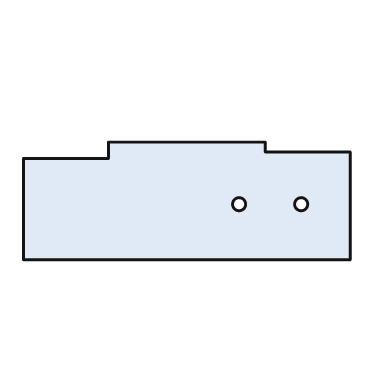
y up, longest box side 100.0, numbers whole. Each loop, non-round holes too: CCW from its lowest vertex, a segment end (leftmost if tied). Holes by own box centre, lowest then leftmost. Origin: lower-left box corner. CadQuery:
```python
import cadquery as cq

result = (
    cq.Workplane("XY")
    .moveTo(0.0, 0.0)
    .lineTo(100.0, 0.0)
    .lineTo(100.0, 33.0)
    .lineTo(74.0, 33.0)
    .lineTo(74.0, 36.0)
    .lineTo(26.0, 36.0)
    .lineTo(26.0, 31.0)
    .lineTo(0.0, 31.0)
    .close()
    .moveTo(66.0, 17.0)
    .circle(2.0)
    .moveTo(85.0, 17.0)
    .circle(2.0)
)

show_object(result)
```